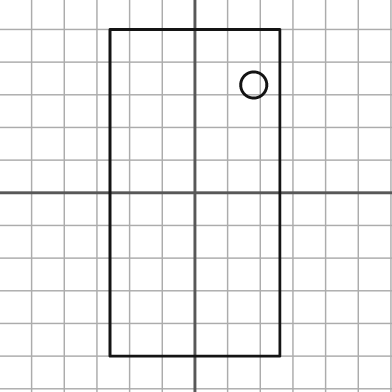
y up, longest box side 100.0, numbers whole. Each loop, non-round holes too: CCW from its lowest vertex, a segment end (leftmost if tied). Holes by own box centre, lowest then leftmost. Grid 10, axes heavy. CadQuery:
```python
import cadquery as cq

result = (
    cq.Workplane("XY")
    .moveTo(-26.0, -50.0)
    .lineTo(26.0, -50.0)
    .lineTo(26.0, 50.0)
    .lineTo(-26.0, 50.0)
    .close()
    .moveTo(18.0, 33.0)
    .circle(4.0)
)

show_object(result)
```